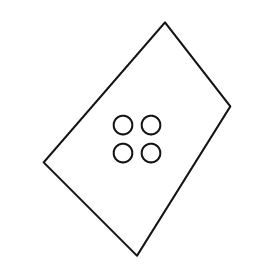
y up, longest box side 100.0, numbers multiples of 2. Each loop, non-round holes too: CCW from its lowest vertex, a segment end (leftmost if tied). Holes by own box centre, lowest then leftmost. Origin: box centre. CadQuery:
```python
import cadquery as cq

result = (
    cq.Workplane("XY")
    .moveTo(0.0, -50.0)
    .lineTo(40.0, 14.0)
    .lineTo(12.0, 50.0)
    .lineTo(-40.0, -10.0)
    .close()
    .moveTo(-6.0, -6.0)
    .circle(4.0)
    .moveTo(6.0, -6.0)
    .circle(4.0)
    .moveTo(-6.0, 6.0)
    .circle(4.0)
    .moveTo(6.0, 6.0)
    .circle(4.0)
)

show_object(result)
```